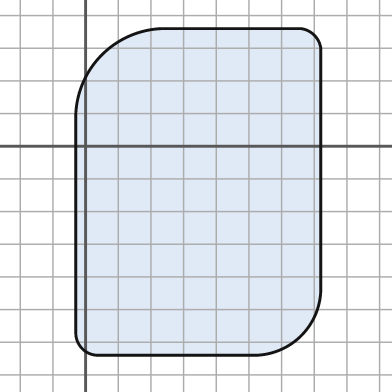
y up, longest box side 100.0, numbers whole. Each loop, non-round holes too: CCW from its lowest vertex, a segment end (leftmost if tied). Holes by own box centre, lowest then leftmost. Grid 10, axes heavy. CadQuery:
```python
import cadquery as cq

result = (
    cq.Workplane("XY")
    .moveTo(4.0, -64.0)
    .lineTo(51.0, -64.0)
    .threePointArc((66.0, -58.0), (72.0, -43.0))
    .lineTo(72.0, 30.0)
    .threePointArc((70.0, 34.0), (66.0, 36.0))
    .lineTo(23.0, 36.0)
    .threePointArc((5.0, 28.0), (-3.0, 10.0))
    .lineTo(-3.0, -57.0)
    .threePointArc((-1.0, -62.0), (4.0, -64.0))
    .close()
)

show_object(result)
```